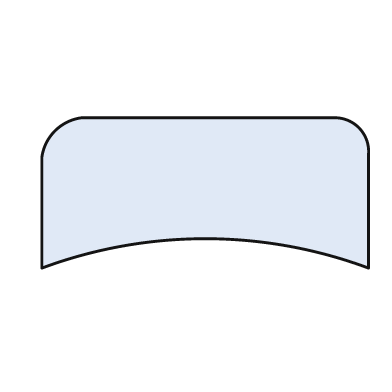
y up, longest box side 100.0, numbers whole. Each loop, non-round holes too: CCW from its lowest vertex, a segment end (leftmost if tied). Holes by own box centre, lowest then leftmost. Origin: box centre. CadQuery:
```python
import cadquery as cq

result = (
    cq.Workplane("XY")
    .moveTo(-50.0, -23.0)
    .threePointArc((0.0, -14.0), (50.0, -23.0))
    .lineTo(50.0, 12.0)
    .threePointArc((47.0, 20.0), (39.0, 23.0))
    .lineTo(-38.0, 23.0)
    .threePointArc((-46.0, 19.0), (-50.0, 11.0))
    .close()
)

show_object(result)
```